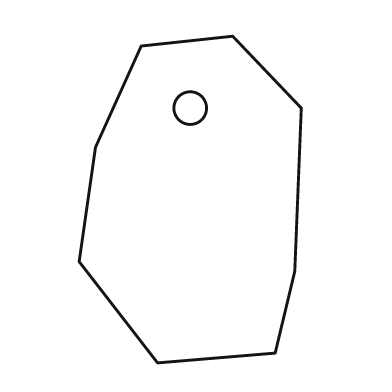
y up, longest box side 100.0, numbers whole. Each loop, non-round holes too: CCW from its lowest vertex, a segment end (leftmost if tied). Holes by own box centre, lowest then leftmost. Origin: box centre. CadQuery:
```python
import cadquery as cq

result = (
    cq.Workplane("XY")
    .moveTo(-10.0, -50.0)
    .lineTo(26.0, -47.0)
    .lineTo(32.0, -22.0)
    .lineTo(34.0, 28.0)
    .lineTo(13.0, 50.0)
    .lineTo(-15.0, 47.0)
    .lineTo(-29.0, 16.0)
    .lineTo(-34.0, -19.0)
    .close()
    .moveTo(0.0, 28.0)
    .circle(5.0)
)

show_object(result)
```